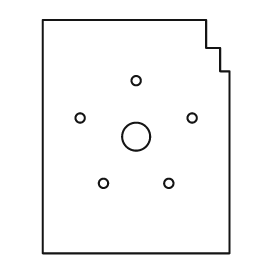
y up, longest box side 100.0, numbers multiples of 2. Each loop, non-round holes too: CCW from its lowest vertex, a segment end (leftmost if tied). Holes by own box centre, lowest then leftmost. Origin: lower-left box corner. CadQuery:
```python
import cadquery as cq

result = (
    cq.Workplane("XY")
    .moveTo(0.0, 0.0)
    .lineTo(80.0, 0.0)
    .lineTo(80.0, 78.0)
    .lineTo(76.0, 78.0)
    .lineTo(76.0, 88.0)
    .lineTo(70.0, 88.0)
    .lineTo(70.0, 100.0)
    .lineTo(0.0, 100.0)
    .close()
    .moveTo(26.0, 30.0)
    .circle(2.0)
    .moveTo(54.0, 30.0)
    .circle(2.0)
    .moveTo(40.0, 50.0)
    .circle(6.0)
    .moveTo(16.0, 58.0)
    .circle(2.0)
    .moveTo(64.0, 58.0)
    .circle(2.0)
    .moveTo(40.0, 74.0)
    .circle(2.0)
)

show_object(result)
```